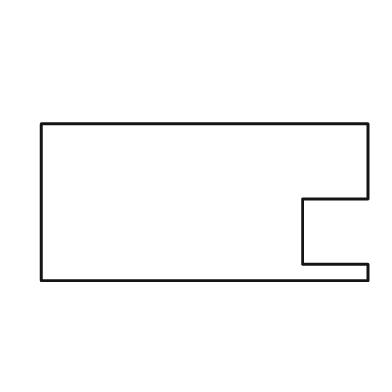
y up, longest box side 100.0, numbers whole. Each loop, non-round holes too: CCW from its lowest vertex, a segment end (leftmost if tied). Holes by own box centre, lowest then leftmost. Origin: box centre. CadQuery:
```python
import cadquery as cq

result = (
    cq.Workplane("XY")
    .moveTo(-50.0, -24.0)
    .lineTo(50.0, -24.0)
    .lineTo(50.0, -19.0)
    .lineTo(30.0, -19.0)
    .lineTo(30.0, 1.0)
    .lineTo(50.0, 1.0)
    .lineTo(50.0, 24.0)
    .lineTo(-50.0, 24.0)
    .close()
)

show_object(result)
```